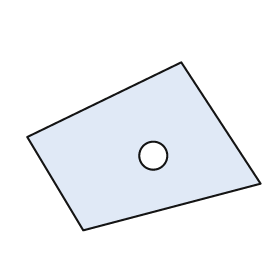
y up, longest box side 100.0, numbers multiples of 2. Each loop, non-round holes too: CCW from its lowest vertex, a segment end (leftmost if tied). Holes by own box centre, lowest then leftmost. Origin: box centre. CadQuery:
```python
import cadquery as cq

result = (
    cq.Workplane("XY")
    .moveTo(-26.0, -36.0)
    .lineTo(50.0, -16.0)
    .lineTo(16.0, 36.0)
    .lineTo(-50.0, 4.0)
    .close()
    .moveTo(4.0, -4.0)
    .circle(6.0)
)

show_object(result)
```